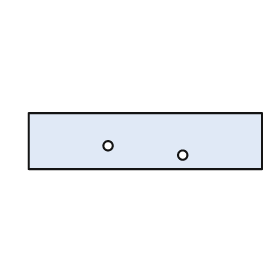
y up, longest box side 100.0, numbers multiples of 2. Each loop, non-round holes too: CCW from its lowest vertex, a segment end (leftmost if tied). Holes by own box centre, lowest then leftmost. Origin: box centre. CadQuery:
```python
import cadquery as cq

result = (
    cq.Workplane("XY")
    .moveTo(-50.0, -12.0)
    .lineTo(50.0, -12.0)
    .lineTo(50.0, 12.0)
    .lineTo(-50.0, 12.0)
    .close()
    .moveTo(16.0, -6.0)
    .circle(2.0)
    .moveTo(-16.0, -2.0)
    .circle(2.0)
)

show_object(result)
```